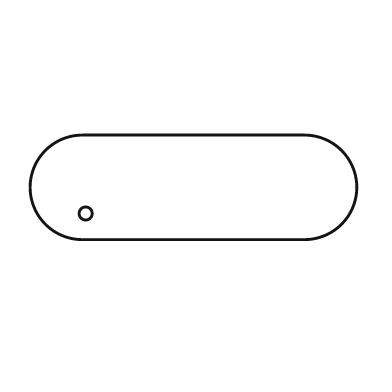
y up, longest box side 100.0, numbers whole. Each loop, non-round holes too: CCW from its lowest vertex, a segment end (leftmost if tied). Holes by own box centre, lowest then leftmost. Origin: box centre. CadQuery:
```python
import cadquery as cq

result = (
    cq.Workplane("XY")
    .moveTo(-34.0, -16.0)
    .lineTo(34.0, -16.0)
    .threePointArc((50.0, 0.0), (34.0, 16.0))
    .lineTo(-34.0, 16.0)
    .threePointArc((-50.0, 0.0), (-34.0, -16.0))
    .close()
    .moveTo(-33.0, -8.0)
    .circle(2.0)
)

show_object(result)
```